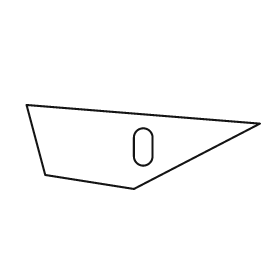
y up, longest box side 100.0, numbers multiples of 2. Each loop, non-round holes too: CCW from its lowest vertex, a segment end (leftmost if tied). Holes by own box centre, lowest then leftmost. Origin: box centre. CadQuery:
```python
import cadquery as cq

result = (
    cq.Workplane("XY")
    .moveTo(-4.0, -18.0)
    .lineTo(50.0, 10.0)
    .lineTo(-50.0, 18.0)
    .lineTo(-42.0, -12.0)
    .close()
    .moveTo(-4.0, -4.0)
    .threePointArc((0.0, -8.0), (4.0, -4.0))
    .lineTo(4.0, 4.0)
    .threePointArc((0.0, 8.0), (-4.0, 4.0))
    .close()
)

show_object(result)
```